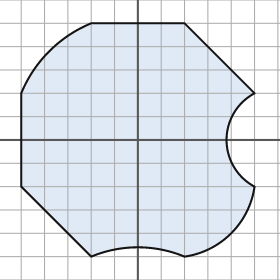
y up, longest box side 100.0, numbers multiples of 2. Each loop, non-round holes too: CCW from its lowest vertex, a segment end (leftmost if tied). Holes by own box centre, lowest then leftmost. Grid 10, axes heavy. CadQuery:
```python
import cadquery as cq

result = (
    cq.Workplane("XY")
    .moveTo(-20.0, -50.0)
    .threePointArc((0.0, -46.0), (20.0, -50.0))
    .threePointArc((40.0, -40.0), (50.0, -20.0))
    .threePointArc((38.0, 0.0), (50.0, 20.0))
    .lineTo(20.0, 50.0)
    .lineTo(-20.0, 50.0)
    .threePointArc((-38.0, 38.0), (-50.0, 20.0))
    .lineTo(-50.0, -20.0)
    .close()
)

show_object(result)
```